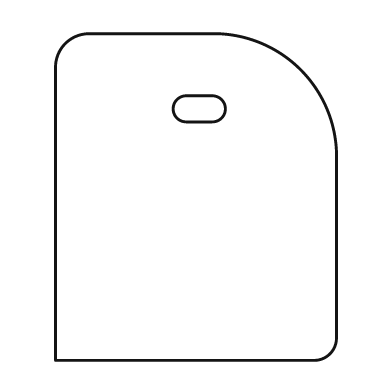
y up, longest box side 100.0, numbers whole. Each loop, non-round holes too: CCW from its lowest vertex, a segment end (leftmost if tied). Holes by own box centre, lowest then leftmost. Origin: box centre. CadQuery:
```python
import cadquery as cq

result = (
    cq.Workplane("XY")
    .moveTo(-43.0, -50.0)
    .lineTo(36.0, -50.0)
    .threePointArc((41.0, -48.0), (43.0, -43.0))
    .lineTo(43.0, 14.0)
    .threePointArc((32.0, 39.0), (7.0, 50.0))
    .lineTo(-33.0, 50.0)
    .threePointArc((-40.0, 47.0), (-43.0, 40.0))
    .close()
    .moveTo(-3.0, 23.0)
    .lineTo(5.0, 23.0)
    .threePointArc((9.0, 27.0), (5.0, 31.0))
    .lineTo(-3.0, 31.0)
    .threePointArc((-7.0, 27.0), (-3.0, 23.0))
    .close()
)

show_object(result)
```